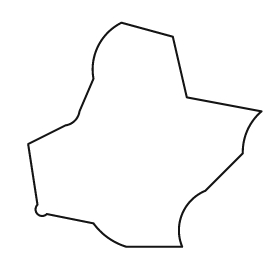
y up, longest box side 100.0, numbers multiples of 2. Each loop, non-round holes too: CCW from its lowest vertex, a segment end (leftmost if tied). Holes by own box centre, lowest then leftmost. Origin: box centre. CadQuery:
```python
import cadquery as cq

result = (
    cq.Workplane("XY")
    .moveTo(-8.0, -48.0)
    .lineTo(16.0, -48.0)
    .threePointArc((16.0, -34.0), (26.0, -24.0))
    .lineTo(42.0, -8.0)
    .threePointArc((44.0, 2.0), (50.0, 10.0))
    .lineTo(18.0, 16.0)
    .lineTo(12.0, 42.0)
    .lineTo(-10.0, 48.0)
    .threePointArc((-20.0, 38.0), (-22.0, 24.0))
    .lineTo(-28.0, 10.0)
    .threePointArc((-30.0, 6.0), (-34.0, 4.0))
    .lineTo(-50.0, -4.0)
    .lineTo(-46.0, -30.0)
    .threePointArc((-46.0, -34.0), (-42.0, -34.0))
    .lineTo(-22.0, -38.0)
    .threePointArc((-16.0, -44.0), (-8.0, -48.0))
    .close()
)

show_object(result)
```